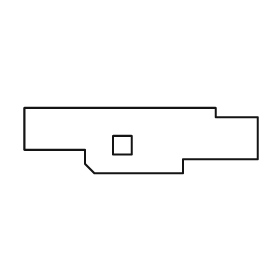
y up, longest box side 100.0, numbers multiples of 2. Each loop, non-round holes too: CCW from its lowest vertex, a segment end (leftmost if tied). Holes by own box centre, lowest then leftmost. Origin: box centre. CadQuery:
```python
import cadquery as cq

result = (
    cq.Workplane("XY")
    .moveTo(-20.0, -14.0)
    .lineTo(18.0, -14.0)
    .lineTo(18.0, -8.0)
    .lineTo(50.0, -8.0)
    .lineTo(50.0, 10.0)
    .lineTo(32.0, 10.0)
    .lineTo(32.0, 14.0)
    .lineTo(-50.0, 14.0)
    .lineTo(-50.0, -4.0)
    .lineTo(-24.0, -4.0)
    .lineTo(-24.0, -10.0)
    .close()
    .moveTo(-12.0, -6.0)
    .lineTo(-4.0, -6.0)
    .lineTo(-4.0, 2.0)
    .lineTo(-12.0, 2.0)
    .close()
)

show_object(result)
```